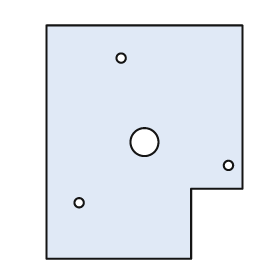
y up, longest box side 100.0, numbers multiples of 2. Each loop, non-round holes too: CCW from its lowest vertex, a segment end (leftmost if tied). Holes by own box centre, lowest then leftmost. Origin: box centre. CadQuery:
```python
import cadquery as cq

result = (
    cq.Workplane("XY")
    .moveTo(-42.0, -50.0)
    .lineTo(20.0, -50.0)
    .lineTo(20.0, -20.0)
    .lineTo(42.0, -20.0)
    .lineTo(42.0, 50.0)
    .lineTo(-42.0, 50.0)
    .close()
    .moveTo(-28.0, -26.0)
    .circle(2.0)
    .moveTo(36.0, -10.0)
    .circle(2.0)
    .moveTo(0.0, 0.0)
    .circle(6.0)
    .moveTo(-10.0, 36.0)
    .circle(2.0)
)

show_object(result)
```